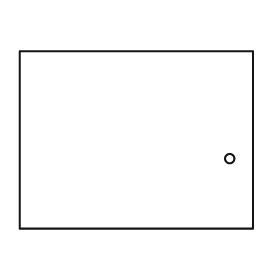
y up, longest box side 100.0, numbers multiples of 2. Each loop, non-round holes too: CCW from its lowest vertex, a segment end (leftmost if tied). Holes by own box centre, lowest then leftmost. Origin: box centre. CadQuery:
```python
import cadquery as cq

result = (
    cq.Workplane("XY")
    .moveTo(-50.0, -38.0)
    .lineTo(50.0, -38.0)
    .lineTo(50.0, 38.0)
    .lineTo(-50.0, 38.0)
    .close()
    .moveTo(40.0, -8.0)
    .circle(2.0)
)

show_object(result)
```